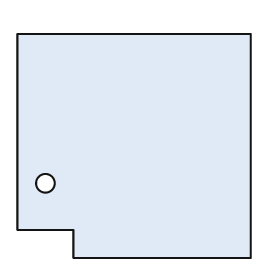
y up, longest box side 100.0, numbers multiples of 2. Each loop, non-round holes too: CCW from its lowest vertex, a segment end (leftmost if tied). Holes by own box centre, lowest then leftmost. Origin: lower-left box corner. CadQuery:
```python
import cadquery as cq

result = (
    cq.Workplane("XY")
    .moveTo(24.0, 0.0)
    .lineTo(100.0, 0.0)
    .lineTo(100.0, 96.0)
    .lineTo(0.0, 96.0)
    .lineTo(0.0, 12.0)
    .lineTo(24.0, 12.0)
    .close()
    .moveTo(12.0, 32.0)
    .circle(4.0)
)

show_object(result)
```